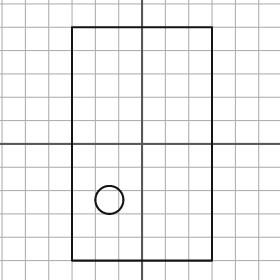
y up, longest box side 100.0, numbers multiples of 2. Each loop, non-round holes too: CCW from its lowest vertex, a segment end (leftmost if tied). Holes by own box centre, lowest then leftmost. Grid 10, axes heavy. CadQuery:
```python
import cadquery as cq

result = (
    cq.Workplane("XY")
    .moveTo(-30.0, -50.0)
    .lineTo(30.0, -50.0)
    .lineTo(30.0, 50.0)
    .lineTo(-30.0, 50.0)
    .close()
    .moveTo(-14.0, -24.0)
    .circle(6.0)
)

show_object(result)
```